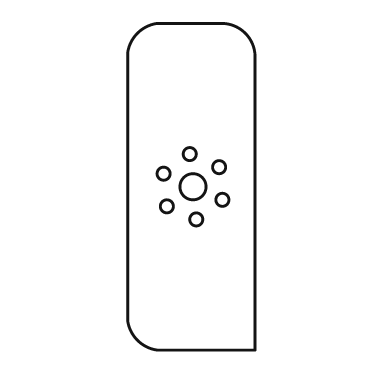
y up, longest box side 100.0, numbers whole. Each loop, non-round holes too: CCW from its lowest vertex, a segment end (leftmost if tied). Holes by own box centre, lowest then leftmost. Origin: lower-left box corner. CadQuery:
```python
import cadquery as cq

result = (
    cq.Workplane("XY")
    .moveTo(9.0, 0.0)
    .lineTo(39.0, 0.0)
    .lineTo(39.0, 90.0)
    .threePointArc((36.0, 97.0), (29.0, 100.0))
    .lineTo(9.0, 100.0)
    .threePointArc((3.0, 97.0), (0.0, 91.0))
    .lineTo(0.0, 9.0)
    .threePointArc((3.0, 3.0), (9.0, 0.0))
    .close()
    .moveTo(21.0, 40.0)
    .circle(2.0)
    .moveTo(12.0, 44.0)
    .circle(2.0)
    .moveTo(29.0, 46.0)
    .circle(2.0)
    .moveTo(20.0, 50.0)
    .circle(4.0)
    .moveTo(11.0, 54.0)
    .circle(2.0)
    .moveTo(28.0, 56.0)
    .circle(2.0)
    .moveTo(19.0, 60.0)
    .circle(2.0)
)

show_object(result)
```